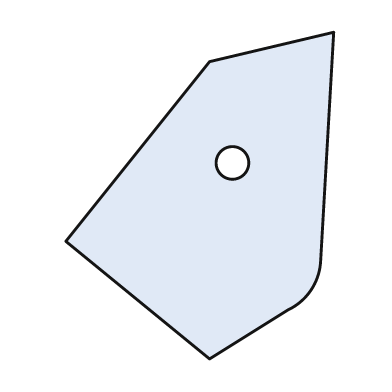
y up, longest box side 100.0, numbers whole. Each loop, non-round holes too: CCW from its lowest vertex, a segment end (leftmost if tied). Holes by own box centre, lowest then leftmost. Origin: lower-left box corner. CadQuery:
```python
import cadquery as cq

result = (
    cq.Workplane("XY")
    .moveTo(44.0, 0.0)
    .lineTo(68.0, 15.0)
    .threePointArc((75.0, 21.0), (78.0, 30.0))
    .lineTo(82.0, 100.0)
    .lineTo(44.0, 91.0)
    .lineTo(0.0, 36.0)
    .close()
    .moveTo(51.0, 60.0)
    .circle(5.0)
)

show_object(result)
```